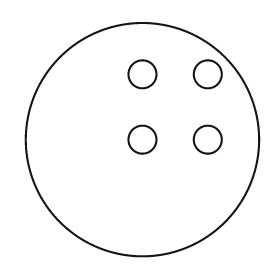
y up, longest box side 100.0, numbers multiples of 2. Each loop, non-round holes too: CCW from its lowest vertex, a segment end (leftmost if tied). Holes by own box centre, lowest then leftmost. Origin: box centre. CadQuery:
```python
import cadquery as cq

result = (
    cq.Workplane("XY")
    .moveTo(0.0, 0.0)
    .circle(50.0)
    .moveTo(0.0, 0.0)
    .circle(6.0)
    .moveTo(28.0, 0.0)
    .circle(6.0)
    .moveTo(0.0, 28.0)
    .circle(6.0)
    .moveTo(28.0, 28.0)
    .circle(6.0)
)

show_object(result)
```